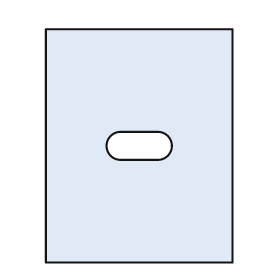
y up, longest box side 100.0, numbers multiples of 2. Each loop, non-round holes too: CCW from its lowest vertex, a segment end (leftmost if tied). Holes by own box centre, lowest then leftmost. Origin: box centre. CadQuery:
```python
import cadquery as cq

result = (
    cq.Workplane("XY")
    .moveTo(-40.0, -50.0)
    .lineTo(40.0, -50.0)
    .lineTo(40.0, 50.0)
    .lineTo(-40.0, 50.0)
    .close()
    .moveTo(-8.0, -6.0)
    .lineTo(8.0, -6.0)
    .threePointArc((14.0, 0.0), (8.0, 6.0))
    .lineTo(-8.0, 6.0)
    .threePointArc((-14.0, 0.0), (-8.0, -6.0))
    .close()
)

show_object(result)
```